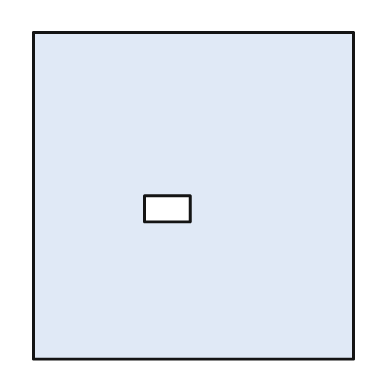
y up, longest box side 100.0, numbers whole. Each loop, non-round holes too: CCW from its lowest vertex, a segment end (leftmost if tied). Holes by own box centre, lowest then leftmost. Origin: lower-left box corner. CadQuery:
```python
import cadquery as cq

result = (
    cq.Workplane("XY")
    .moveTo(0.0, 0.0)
    .lineTo(98.0, 0.0)
    .lineTo(98.0, 100.0)
    .lineTo(0.0, 100.0)
    .close()
    .moveTo(34.0, 42.0)
    .lineTo(48.0, 42.0)
    .lineTo(48.0, 50.0)
    .lineTo(34.0, 50.0)
    .close()
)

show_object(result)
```